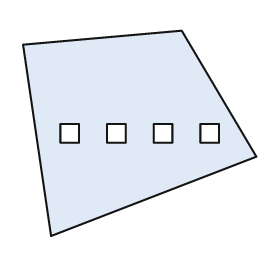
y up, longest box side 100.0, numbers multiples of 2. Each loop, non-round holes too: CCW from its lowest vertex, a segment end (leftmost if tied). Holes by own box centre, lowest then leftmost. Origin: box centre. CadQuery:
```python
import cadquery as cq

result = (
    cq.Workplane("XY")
    .moveTo(-38.0, -44.0)
    .lineTo(50.0, -10.0)
    .lineTo(18.0, 44.0)
    .lineTo(-50.0, 38.0)
    .close()
    .moveTo(-34.0, -4.0)
    .lineTo(-26.0, -4.0)
    .lineTo(-26.0, 4.0)
    .lineTo(-34.0, 4.0)
    .close()
    .moveTo(-14.0, -4.0)
    .lineTo(-6.0, -4.0)
    .lineTo(-6.0, 4.0)
    .lineTo(-14.0, 4.0)
    .close()
    .moveTo(6.0, -4.0)
    .lineTo(14.0, -4.0)
    .lineTo(14.0, 4.0)
    .lineTo(6.0, 4.0)
    .close()
    .moveTo(26.0, -4.0)
    .lineTo(34.0, -4.0)
    .lineTo(34.0, 4.0)
    .lineTo(26.0, 4.0)
    .close()
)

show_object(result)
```